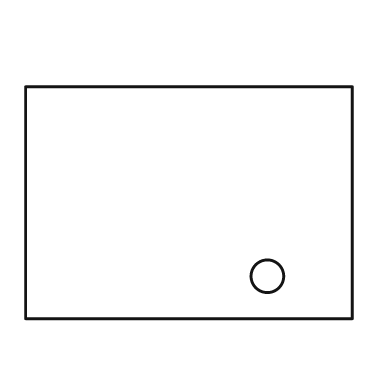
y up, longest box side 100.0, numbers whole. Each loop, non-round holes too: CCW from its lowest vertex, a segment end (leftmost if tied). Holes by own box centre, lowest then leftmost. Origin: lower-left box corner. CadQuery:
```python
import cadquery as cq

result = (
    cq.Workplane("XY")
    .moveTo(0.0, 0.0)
    .lineTo(100.0, 0.0)
    .lineTo(100.0, 71.0)
    .lineTo(0.0, 71.0)
    .close()
    .moveTo(74.0, 13.0)
    .circle(5.0)
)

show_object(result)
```